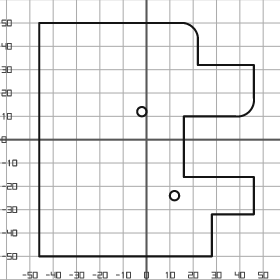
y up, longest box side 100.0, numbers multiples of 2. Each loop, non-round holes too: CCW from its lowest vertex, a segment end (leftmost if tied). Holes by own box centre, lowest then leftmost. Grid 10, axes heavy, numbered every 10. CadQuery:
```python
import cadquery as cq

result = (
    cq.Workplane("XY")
    .moveTo(-46.0, -50.0)
    .lineTo(28.0, -50.0)
    .lineTo(28.0, -32.0)
    .lineTo(46.0, -32.0)
    .lineTo(46.0, -16.0)
    .lineTo(16.0, -16.0)
    .lineTo(16.0, 10.0)
    .lineTo(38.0, 10.0)
    .threePointArc((44.0, 12.0), (46.0, 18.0))
    .lineTo(46.0, 32.0)
    .lineTo(22.0, 32.0)
    .lineTo(22.0, 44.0)
    .threePointArc((20.0, 48.0), (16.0, 50.0))
    .lineTo(-46.0, 50.0)
    .close()
    .moveTo(12.0, -24.0)
    .circle(2.0)
    .moveTo(-2.0, 12.0)
    .circle(2.0)
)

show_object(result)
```